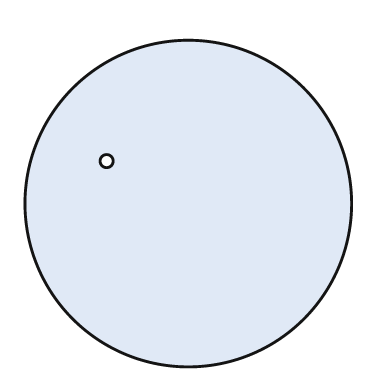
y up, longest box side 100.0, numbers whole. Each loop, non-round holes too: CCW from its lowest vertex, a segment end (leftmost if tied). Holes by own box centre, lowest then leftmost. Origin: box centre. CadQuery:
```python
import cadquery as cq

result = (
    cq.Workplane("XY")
    .moveTo(0.0, 0.0)
    .circle(50.0)
    .moveTo(-25.0, 13.0)
    .circle(2.0)
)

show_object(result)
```